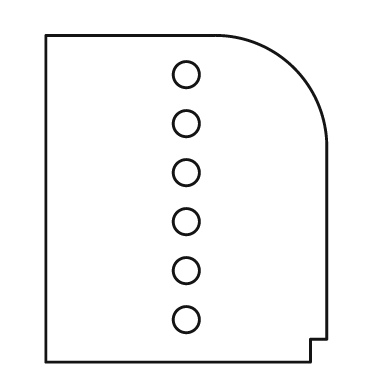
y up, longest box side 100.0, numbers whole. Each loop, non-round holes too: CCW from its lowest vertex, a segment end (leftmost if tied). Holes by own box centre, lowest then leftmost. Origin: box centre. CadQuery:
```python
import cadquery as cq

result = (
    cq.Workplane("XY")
    .moveTo(-43.0, -50.0)
    .lineTo(38.0, -50.0)
    .lineTo(38.0, -43.0)
    .lineTo(43.0, -43.0)
    .lineTo(43.0, 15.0)
    .threePointArc((33.0, 40.0), (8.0, 50.0))
    .lineTo(-43.0, 50.0)
    .close()
    .moveTo(0.0, -37.0)
    .circle(4.0)
    .moveTo(0.0, -22.0)
    .circle(4.0)
    .moveTo(0.0, -7.0)
    .circle(4.0)
    .moveTo(0.0, 8.0)
    .circle(4.0)
    .moveTo(0.0, 23.0)
    .circle(4.0)
    .moveTo(0.0, 38.0)
    .circle(4.0)
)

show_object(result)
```